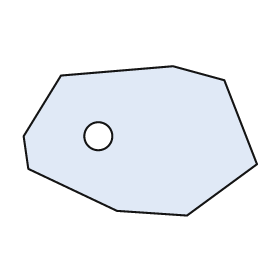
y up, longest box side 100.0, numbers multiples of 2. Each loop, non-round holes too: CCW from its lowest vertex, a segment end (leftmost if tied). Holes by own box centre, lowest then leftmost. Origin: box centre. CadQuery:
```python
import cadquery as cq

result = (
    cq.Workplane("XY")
    .moveTo(20.0, -32.0)
    .lineTo(50.0, -10.0)
    .lineTo(36.0, 26.0)
    .lineTo(14.0, 32.0)
    .lineTo(-34.0, 28.0)
    .lineTo(-50.0, 2.0)
    .lineTo(-48.0, -12.0)
    .lineTo(-10.0, -30.0)
    .close()
    .moveTo(-18.0, 2.0)
    .circle(6.0)
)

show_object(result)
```